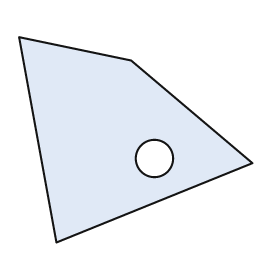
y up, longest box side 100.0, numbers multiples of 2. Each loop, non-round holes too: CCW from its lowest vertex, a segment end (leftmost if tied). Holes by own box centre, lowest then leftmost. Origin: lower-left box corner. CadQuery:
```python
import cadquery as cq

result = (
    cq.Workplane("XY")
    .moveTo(16.0, 0.0)
    .lineTo(100.0, 34.0)
    .lineTo(48.0, 78.0)
    .lineTo(0.0, 88.0)
    .close()
    .moveTo(58.0, 36.0)
    .circle(8.0)
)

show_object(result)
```